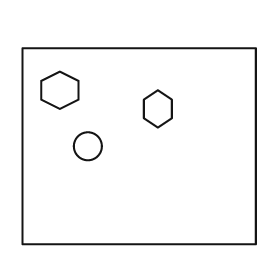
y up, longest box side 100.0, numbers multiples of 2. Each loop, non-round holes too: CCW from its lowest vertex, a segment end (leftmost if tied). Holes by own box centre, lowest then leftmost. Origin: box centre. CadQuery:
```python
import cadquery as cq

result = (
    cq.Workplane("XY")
    .moveTo(-50.0, -42.0)
    .lineTo(50.0, -42.0)
    .lineTo(50.0, 42.0)
    .lineTo(-50.0, 42.0)
    .close()
    .moveTo(-22.0, 0.0)
    .circle(6.0)
    .moveTo(8.0, 8.0)
    .lineTo(14.0, 12.0)
    .lineTo(14.0, 20.0)
    .lineTo(8.0, 24.0)
    .lineTo(2.0, 20.0)
    .lineTo(2.0, 12.0)
    .close()
    .moveTo(-34.0, 16.0)
    .lineTo(-26.0, 20.0)
    .lineTo(-26.0, 28.0)
    .lineTo(-34.0, 32.0)
    .lineTo(-42.0, 28.0)
    .lineTo(-42.0, 20.0)
    .close()
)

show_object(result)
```